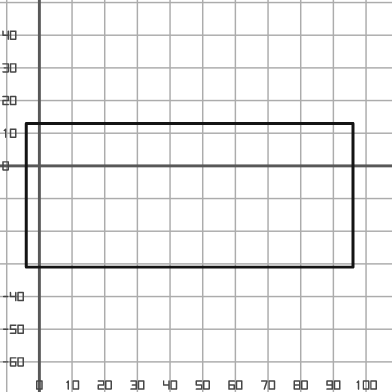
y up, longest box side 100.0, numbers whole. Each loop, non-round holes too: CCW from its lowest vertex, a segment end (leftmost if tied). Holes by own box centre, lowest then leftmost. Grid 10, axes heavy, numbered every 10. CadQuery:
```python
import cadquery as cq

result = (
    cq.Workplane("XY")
    .moveTo(-4.0, -31.0)
    .lineTo(96.0, -31.0)
    .lineTo(96.0, 13.0)
    .lineTo(-4.0, 13.0)
    .close()
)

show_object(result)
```